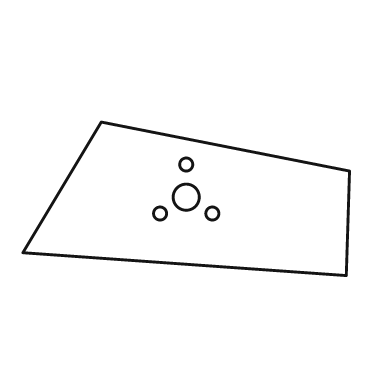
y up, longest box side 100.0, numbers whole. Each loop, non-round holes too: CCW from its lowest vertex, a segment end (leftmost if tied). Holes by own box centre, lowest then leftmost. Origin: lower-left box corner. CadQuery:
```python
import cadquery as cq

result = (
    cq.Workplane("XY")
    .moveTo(99.0, 0.0)
    .lineTo(100.0, 32.0)
    .lineTo(24.0, 47.0)
    .lineTo(0.0, 7.0)
    .close()
    .moveTo(42.0, 19.0)
    .circle(2.0)
    .moveTo(58.0, 19.0)
    .circle(2.0)
    .moveTo(50.0, 24.0)
    .circle(4.0)
    .moveTo(50.0, 34.0)
    .circle(2.0)
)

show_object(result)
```